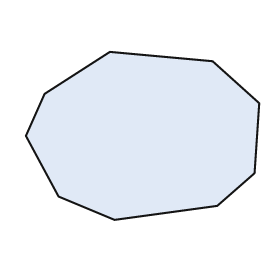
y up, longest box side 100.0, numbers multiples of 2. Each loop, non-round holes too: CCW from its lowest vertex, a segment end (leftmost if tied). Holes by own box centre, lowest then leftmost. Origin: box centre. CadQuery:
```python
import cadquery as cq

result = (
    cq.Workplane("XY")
    .moveTo(-12.0, -36.0)
    .lineTo(32.0, -30.0)
    .lineTo(48.0, -16.0)
    .lineTo(50.0, 14.0)
    .lineTo(30.0, 32.0)
    .lineTo(-14.0, 36.0)
    .lineTo(-42.0, 18.0)
    .lineTo(-50.0, 0.0)
    .lineTo(-36.0, -26.0)
    .close()
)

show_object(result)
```